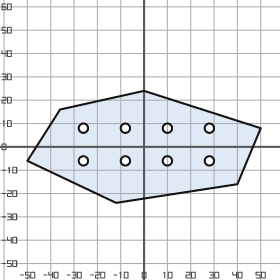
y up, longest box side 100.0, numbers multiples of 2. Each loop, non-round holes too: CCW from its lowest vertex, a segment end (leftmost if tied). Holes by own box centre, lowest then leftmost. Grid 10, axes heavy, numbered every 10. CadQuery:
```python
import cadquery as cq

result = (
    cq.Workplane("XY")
    .moveTo(-12.0, -24.0)
    .lineTo(40.0, -16.0)
    .lineTo(50.0, 8.0)
    .lineTo(0.0, 24.0)
    .lineTo(-36.0, 16.0)
    .lineTo(-50.0, -6.0)
    .close()
    .moveTo(-26.0, -6.0)
    .circle(2.0)
    .moveTo(-8.0, -6.0)
    .circle(2.0)
    .moveTo(10.0, -6.0)
    .circle(2.0)
    .moveTo(28.0, -6.0)
    .circle(2.0)
    .moveTo(-26.0, 8.0)
    .circle(2.0)
    .moveTo(-8.0, 8.0)
    .circle(2.0)
    .moveTo(10.0, 8.0)
    .circle(2.0)
    .moveTo(28.0, 8.0)
    .circle(2.0)
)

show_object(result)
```